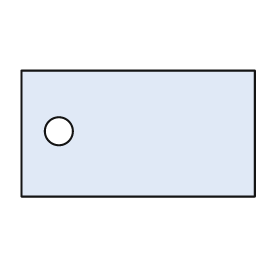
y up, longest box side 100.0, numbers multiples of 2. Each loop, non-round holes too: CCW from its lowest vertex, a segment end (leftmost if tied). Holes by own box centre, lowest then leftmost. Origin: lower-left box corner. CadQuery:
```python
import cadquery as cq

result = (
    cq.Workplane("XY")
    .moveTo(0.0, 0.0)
    .lineTo(100.0, 0.0)
    .lineTo(100.0, 54.0)
    .lineTo(0.0, 54.0)
    .close()
    .moveTo(16.0, 28.0)
    .circle(6.0)
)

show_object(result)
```